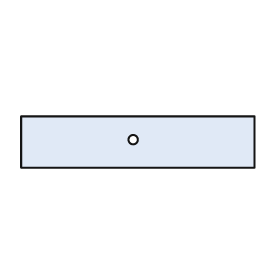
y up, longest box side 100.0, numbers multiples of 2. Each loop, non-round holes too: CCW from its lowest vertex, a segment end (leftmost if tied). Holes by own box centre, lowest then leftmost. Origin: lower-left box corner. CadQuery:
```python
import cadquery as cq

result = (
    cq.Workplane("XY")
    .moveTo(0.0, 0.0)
    .lineTo(100.0, 0.0)
    .lineTo(100.0, 22.0)
    .lineTo(0.0, 22.0)
    .close()
    .moveTo(48.0, 12.0)
    .circle(2.0)
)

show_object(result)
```